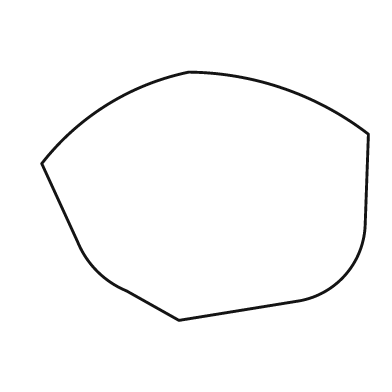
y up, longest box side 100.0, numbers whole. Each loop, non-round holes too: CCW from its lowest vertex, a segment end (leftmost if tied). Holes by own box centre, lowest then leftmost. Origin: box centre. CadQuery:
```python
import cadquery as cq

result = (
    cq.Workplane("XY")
    .moveTo(-8.0, -38.0)
    .lineTo(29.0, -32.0)
    .threePointArc((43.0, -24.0), (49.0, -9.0))
    .lineTo(50.0, 19.0)
    .threePointArc((24.0, 33.0), (-5.0, 38.0))
    .threePointArc((-30.0, 28.0), (-50.0, 10.0))
    .lineTo(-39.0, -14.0)
    .threePointArc((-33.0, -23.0), (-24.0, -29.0))
    .close()
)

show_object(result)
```